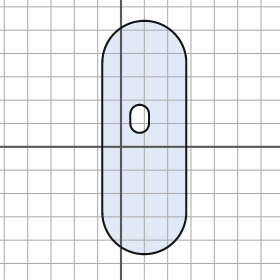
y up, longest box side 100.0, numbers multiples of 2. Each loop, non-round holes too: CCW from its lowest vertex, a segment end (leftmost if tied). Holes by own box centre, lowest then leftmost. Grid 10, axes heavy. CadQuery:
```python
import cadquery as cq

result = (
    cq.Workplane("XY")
    .moveTo(-8.0, -28.0)
    .threePointArc((10.0, -46.0), (28.0, -28.0))
    .lineTo(28.0, 36.0)
    .threePointArc((10.0, 54.0), (-8.0, 36.0))
    .close()
    .moveTo(4.0, 10.0)
    .threePointArc((8.0, 6.0), (12.0, 10.0))
    .lineTo(12.0, 14.0)
    .threePointArc((8.0, 18.0), (4.0, 14.0))
    .close()
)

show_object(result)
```